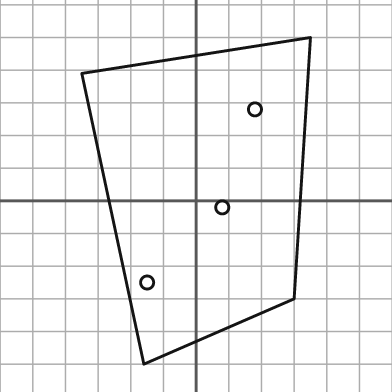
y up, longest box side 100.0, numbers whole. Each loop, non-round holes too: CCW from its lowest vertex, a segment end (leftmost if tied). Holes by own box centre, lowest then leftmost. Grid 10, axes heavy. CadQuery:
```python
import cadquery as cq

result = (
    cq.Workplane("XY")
    .moveTo(-16.0, -50.0)
    .lineTo(30.0, -30.0)
    .lineTo(35.0, 50.0)
    .lineTo(-35.0, 39.0)
    .close()
    .moveTo(-15.0, -25.0)
    .circle(2.0)
    .moveTo(8.0, -2.0)
    .circle(2.0)
    .moveTo(18.0, 28.0)
    .circle(2.0)
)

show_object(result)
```